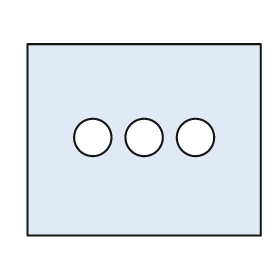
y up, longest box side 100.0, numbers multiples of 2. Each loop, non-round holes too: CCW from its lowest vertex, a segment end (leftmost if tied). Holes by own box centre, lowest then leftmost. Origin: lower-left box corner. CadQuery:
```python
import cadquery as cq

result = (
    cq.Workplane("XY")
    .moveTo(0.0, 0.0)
    .lineTo(100.0, 0.0)
    .lineTo(100.0, 82.0)
    .lineTo(0.0, 82.0)
    .close()
    .moveTo(28.0, 42.0)
    .circle(8.0)
    .moveTo(50.0, 42.0)
    .circle(8.0)
    .moveTo(72.0, 42.0)
    .circle(8.0)
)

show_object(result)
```